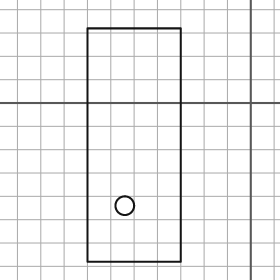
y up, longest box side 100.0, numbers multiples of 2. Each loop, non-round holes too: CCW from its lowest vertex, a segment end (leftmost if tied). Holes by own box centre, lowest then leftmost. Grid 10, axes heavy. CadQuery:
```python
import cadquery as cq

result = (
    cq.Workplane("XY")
    .moveTo(-70.0, -68.0)
    .lineTo(-30.0, -68.0)
    .lineTo(-30.0, 32.0)
    .lineTo(-70.0, 32.0)
    .close()
    .moveTo(-54.0, -44.0)
    .circle(4.0)
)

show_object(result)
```